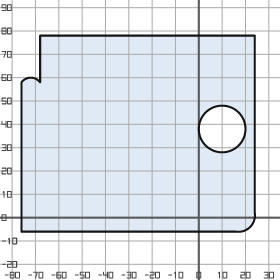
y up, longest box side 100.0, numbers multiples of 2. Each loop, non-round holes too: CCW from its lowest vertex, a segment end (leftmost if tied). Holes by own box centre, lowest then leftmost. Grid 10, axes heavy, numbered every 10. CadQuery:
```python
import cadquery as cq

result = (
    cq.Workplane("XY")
    .moveTo(-76.0, -6.0)
    .lineTo(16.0, -6.0)
    .threePointArc((22.0, -4.0), (24.0, 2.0))
    .lineTo(24.0, 78.0)
    .lineTo(-68.0, 78.0)
    .lineTo(-68.0, 58.0)
    .threePointArc((-72.0, 60.0), (-76.0, 58.0))
    .close()
    .moveTo(10.0, 38.0)
    .circle(10.0)
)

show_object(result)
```